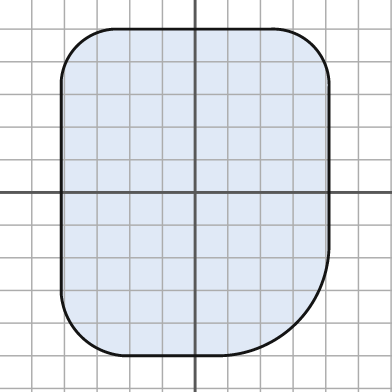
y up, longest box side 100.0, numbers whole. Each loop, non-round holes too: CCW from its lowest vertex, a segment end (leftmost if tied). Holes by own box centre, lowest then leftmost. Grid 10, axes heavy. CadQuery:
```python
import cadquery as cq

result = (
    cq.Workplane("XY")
    .moveTo(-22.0, -50.0)
    .lineTo(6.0, -50.0)
    .threePointArc((31.0, -40.0), (41.0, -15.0))
    .lineTo(41.0, 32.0)
    .threePointArc((36.0, 45.0), (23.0, 50.0))
    .lineTo(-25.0, 50.0)
    .threePointArc((-36.0, 45.0), (-41.0, 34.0))
    .lineTo(-41.0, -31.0)
    .threePointArc((-35.0, -44.0), (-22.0, -50.0))
    .close()
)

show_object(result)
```